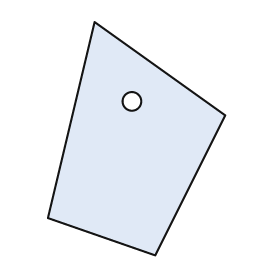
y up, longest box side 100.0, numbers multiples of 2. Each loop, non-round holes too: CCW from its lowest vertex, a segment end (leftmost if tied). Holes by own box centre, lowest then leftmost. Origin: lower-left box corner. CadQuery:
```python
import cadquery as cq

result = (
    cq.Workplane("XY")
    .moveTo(46.0, 0.0)
    .lineTo(76.0, 60.0)
    .lineTo(20.0, 100.0)
    .lineTo(0.0, 16.0)
    .close()
    .moveTo(36.0, 66.0)
    .circle(4.0)
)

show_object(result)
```